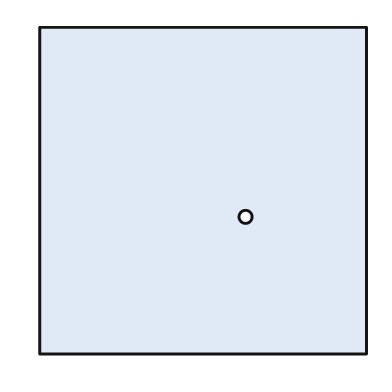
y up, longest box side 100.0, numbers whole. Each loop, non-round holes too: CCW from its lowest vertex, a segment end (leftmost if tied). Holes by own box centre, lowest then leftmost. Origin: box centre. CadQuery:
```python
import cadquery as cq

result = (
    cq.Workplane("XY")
    .moveTo(-50.0, -50.0)
    .lineTo(50.0, -50.0)
    .lineTo(50.0, 50.0)
    .lineTo(-50.0, 50.0)
    .close()
    .moveTo(13.0, -8.0)
    .circle(2.0)
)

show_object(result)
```